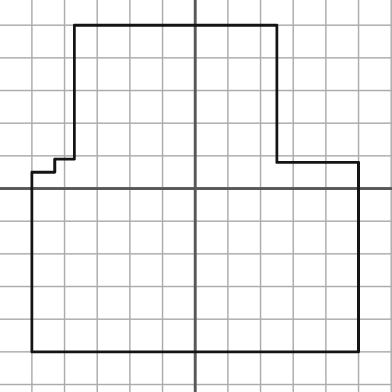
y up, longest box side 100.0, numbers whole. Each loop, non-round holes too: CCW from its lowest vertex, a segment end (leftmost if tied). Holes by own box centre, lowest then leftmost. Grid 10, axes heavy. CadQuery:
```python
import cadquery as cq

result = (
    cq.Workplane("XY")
    .moveTo(-50.0, -50.0)
    .lineTo(50.0, -50.0)
    .lineTo(50.0, 8.0)
    .lineTo(25.0, 8.0)
    .lineTo(25.0, 50.0)
    .lineTo(-37.0, 50.0)
    .lineTo(-37.0, 9.0)
    .lineTo(-43.0, 9.0)
    .lineTo(-43.0, 5.0)
    .lineTo(-50.0, 5.0)
    .close()
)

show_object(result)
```